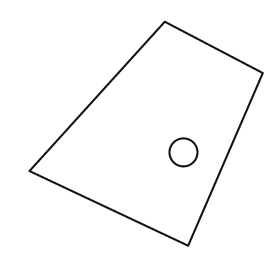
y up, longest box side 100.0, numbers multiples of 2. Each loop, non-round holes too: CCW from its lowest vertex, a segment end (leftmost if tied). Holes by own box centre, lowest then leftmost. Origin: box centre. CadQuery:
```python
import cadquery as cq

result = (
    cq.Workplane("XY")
    .moveTo(18.0, -48.0)
    .lineTo(50.0, 26.0)
    .lineTo(8.0, 48.0)
    .lineTo(-50.0, -16.0)
    .close()
    .moveTo(16.0, -8.0)
    .circle(6.0)
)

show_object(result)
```